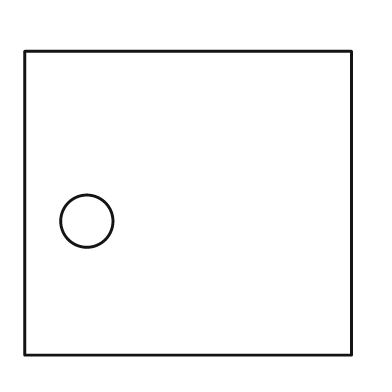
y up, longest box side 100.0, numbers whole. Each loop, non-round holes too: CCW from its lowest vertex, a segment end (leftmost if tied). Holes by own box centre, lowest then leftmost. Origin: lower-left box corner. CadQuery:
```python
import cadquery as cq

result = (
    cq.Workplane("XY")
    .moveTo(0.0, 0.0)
    .lineTo(100.0, 0.0)
    .lineTo(100.0, 93.0)
    .lineTo(0.0, 93.0)
    .close()
    .moveTo(19.0, 41.0)
    .circle(8.0)
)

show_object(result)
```